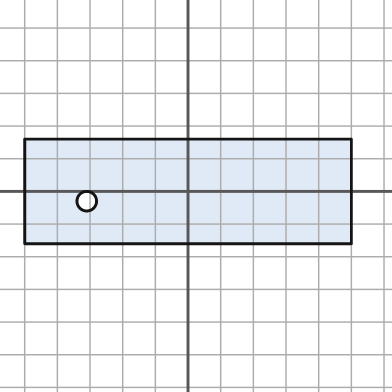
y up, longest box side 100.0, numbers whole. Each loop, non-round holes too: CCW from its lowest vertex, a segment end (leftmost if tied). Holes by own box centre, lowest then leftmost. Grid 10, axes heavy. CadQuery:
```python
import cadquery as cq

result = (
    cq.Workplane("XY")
    .moveTo(-50.0, -16.0)
    .lineTo(50.0, -16.0)
    .lineTo(50.0, 16.0)
    .lineTo(-50.0, 16.0)
    .close()
    .moveTo(-31.0, -3.0)
    .circle(3.0)
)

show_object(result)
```